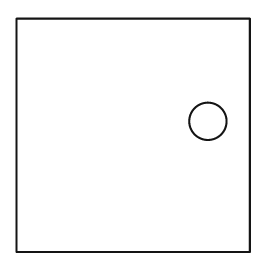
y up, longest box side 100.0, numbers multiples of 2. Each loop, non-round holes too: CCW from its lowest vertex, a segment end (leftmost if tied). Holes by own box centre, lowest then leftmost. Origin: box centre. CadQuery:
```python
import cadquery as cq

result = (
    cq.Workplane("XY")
    .moveTo(-50.0, -50.0)
    .lineTo(50.0, -50.0)
    .lineTo(50.0, 50.0)
    .lineTo(-50.0, 50.0)
    .close()
    .moveTo(32.0, 6.0)
    .circle(8.0)
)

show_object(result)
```